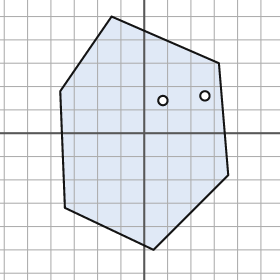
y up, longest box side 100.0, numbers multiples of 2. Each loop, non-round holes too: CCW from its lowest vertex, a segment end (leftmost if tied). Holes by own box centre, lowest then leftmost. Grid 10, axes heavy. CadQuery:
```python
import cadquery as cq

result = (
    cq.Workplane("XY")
    .moveTo(4.0, -50.0)
    .lineTo(36.0, -18.0)
    .lineTo(32.0, 30.0)
    .lineTo(-14.0, 50.0)
    .lineTo(-36.0, 18.0)
    .lineTo(-34.0, -32.0)
    .close()
    .moveTo(8.0, 14.0)
    .circle(2.0)
    .moveTo(26.0, 16.0)
    .circle(2.0)
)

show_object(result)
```